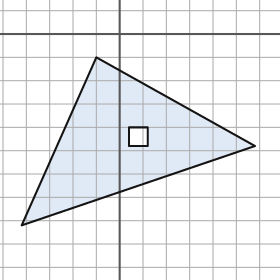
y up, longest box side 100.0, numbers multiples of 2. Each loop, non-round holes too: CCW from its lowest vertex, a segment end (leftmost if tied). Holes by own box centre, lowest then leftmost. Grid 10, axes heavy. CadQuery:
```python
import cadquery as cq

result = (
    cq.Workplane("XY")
    .moveTo(-42.0, -82.0)
    .lineTo(58.0, -48.0)
    .lineTo(-10.0, -10.0)
    .close()
    .moveTo(4.0, -48.0)
    .lineTo(12.0, -48.0)
    .lineTo(12.0, -40.0)
    .lineTo(4.0, -40.0)
    .close()
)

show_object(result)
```